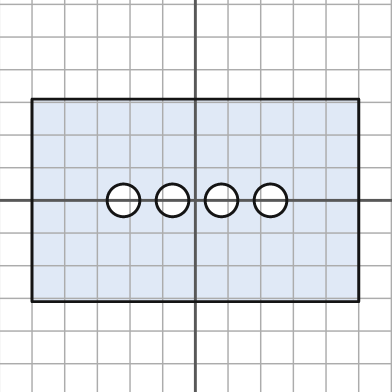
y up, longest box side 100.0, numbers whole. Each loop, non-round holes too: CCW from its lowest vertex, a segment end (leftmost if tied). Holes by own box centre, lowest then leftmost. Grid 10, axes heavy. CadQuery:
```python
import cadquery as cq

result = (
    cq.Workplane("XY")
    .moveTo(-50.0, -31.0)
    .lineTo(50.0, -31.0)
    .lineTo(50.0, 31.0)
    .lineTo(-50.0, 31.0)
    .close()
    .moveTo(-22.0, 0.0)
    .circle(5.0)
    .moveTo(-7.0, 0.0)
    .circle(5.0)
    .moveTo(8.0, 0.0)
    .circle(5.0)
    .moveTo(23.0, 0.0)
    .circle(5.0)
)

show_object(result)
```